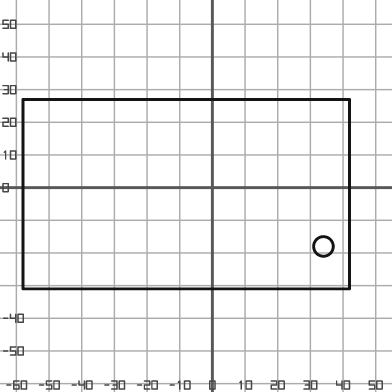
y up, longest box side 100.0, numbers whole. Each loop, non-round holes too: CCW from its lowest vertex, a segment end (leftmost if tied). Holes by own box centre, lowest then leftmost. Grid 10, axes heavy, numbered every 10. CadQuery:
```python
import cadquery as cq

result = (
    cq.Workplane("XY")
    .moveTo(-58.0, -31.0)
    .lineTo(42.0, -31.0)
    .lineTo(42.0, 27.0)
    .lineTo(-58.0, 27.0)
    .close()
    .moveTo(34.0, -18.0)
    .circle(3.0)
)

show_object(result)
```